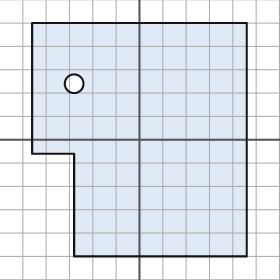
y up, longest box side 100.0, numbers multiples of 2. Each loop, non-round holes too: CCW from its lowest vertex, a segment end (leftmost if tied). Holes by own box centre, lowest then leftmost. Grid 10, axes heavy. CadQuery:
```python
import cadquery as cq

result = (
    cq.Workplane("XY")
    .moveTo(-28.0, -50.0)
    .lineTo(46.0, -50.0)
    .lineTo(46.0, 50.0)
    .lineTo(-46.0, 50.0)
    .lineTo(-46.0, -6.0)
    .lineTo(-28.0, -6.0)
    .close()
    .moveTo(-28.0, 24.0)
    .circle(4.0)
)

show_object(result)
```